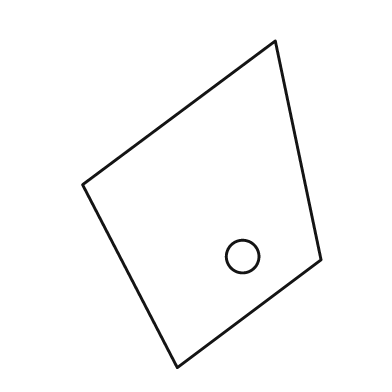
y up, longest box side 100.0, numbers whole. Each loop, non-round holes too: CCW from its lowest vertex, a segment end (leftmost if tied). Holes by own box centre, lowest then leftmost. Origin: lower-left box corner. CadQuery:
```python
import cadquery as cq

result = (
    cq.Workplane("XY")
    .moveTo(29.0, 0.0)
    .lineTo(73.0, 33.0)
    .lineTo(59.0, 100.0)
    .lineTo(0.0, 56.0)
    .close()
    .moveTo(49.0, 34.0)
    .circle(5.0)
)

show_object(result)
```